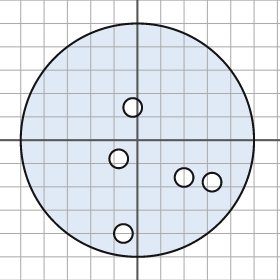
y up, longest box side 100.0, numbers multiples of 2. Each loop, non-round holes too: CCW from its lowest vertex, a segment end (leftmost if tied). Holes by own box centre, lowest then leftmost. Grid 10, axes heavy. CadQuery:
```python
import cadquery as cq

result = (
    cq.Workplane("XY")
    .moveTo(0.0, 0.0)
    .circle(50.0)
    .moveTo(-6.0, -40.0)
    .circle(4.0)
    .moveTo(32.0, -18.0)
    .circle(4.0)
    .moveTo(20.0, -16.0)
    .circle(4.0)
    .moveTo(-8.0, -8.0)
    .circle(4.0)
    .moveTo(-2.0, 14.0)
    .circle(4.0)
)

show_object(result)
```